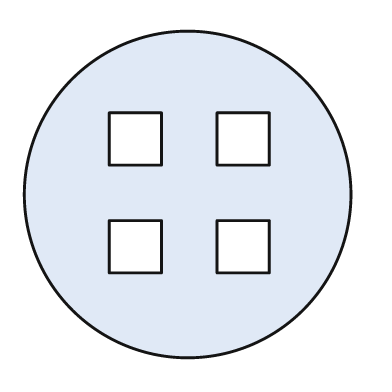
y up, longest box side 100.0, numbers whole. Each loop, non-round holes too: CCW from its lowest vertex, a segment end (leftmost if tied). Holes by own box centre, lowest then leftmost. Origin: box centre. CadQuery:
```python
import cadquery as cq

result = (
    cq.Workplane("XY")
    .moveTo(0.0, 0.0)
    .circle(50.0)
    .moveTo(-24.0, -24.0)
    .lineTo(-8.0, -24.0)
    .lineTo(-8.0, -8.0)
    .lineTo(-24.0, -8.0)
    .close()
    .moveTo(9.0, -24.0)
    .lineTo(25.0, -24.0)
    .lineTo(25.0, -8.0)
    .lineTo(9.0, -8.0)
    .close()
    .moveTo(-24.0, 9.0)
    .lineTo(-8.0, 9.0)
    .lineTo(-8.0, 25.0)
    .lineTo(-24.0, 25.0)
    .close()
    .moveTo(9.0, 9.0)
    .lineTo(25.0, 9.0)
    .lineTo(25.0, 25.0)
    .lineTo(9.0, 25.0)
    .close()
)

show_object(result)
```